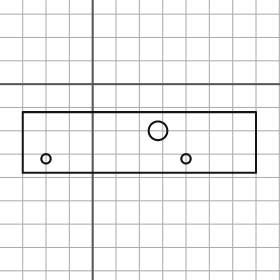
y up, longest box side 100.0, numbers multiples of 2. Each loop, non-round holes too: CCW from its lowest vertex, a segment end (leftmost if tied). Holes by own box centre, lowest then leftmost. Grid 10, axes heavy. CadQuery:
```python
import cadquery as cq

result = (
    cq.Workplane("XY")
    .moveTo(-30.0, -38.0)
    .lineTo(70.0, -38.0)
    .lineTo(70.0, -12.0)
    .lineTo(-30.0, -12.0)
    .close()
    .moveTo(-20.0, -32.0)
    .circle(2.0)
    .moveTo(40.0, -32.0)
    .circle(2.0)
    .moveTo(28.0, -20.0)
    .circle(4.0)
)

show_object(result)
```